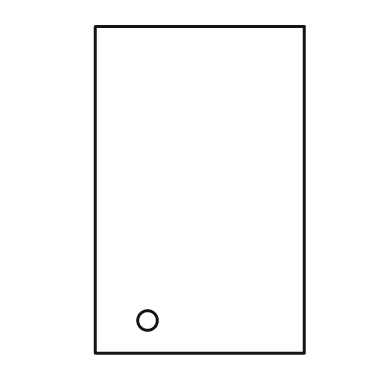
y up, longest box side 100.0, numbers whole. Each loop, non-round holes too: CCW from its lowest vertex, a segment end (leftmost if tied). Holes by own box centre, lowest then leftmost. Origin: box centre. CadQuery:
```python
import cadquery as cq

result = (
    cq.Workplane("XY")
    .moveTo(-32.0, -50.0)
    .lineTo(32.0, -50.0)
    .lineTo(32.0, 50.0)
    .lineTo(-32.0, 50.0)
    .close()
    .moveTo(-16.0, -40.0)
    .circle(3.0)
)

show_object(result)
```